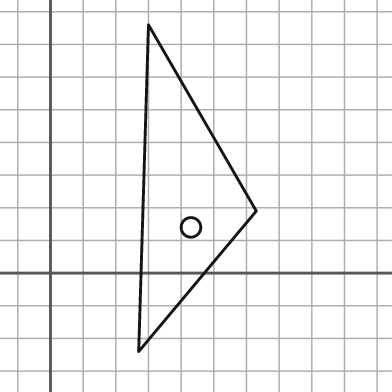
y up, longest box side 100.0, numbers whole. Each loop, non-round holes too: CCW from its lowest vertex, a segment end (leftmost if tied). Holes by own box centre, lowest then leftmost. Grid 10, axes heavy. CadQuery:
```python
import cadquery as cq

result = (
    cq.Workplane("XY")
    .moveTo(27.0, -24.0)
    .lineTo(63.0, 19.0)
    .lineTo(30.0, 76.0)
    .close()
    .moveTo(43.0, 14.0)
    .circle(3.0)
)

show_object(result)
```